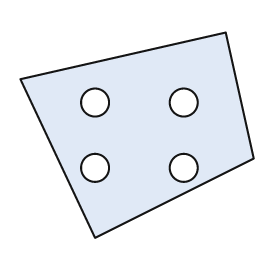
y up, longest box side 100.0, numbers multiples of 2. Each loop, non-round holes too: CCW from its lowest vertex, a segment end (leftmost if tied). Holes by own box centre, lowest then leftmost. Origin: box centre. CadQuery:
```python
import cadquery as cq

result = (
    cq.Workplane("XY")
    .moveTo(-18.0, -44.0)
    .lineTo(50.0, -10.0)
    .lineTo(38.0, 44.0)
    .lineTo(-50.0, 24.0)
    .close()
    .moveTo(-18.0, -14.0)
    .circle(6.0)
    .moveTo(20.0, -14.0)
    .circle(6.0)
    .moveTo(-18.0, 14.0)
    .circle(6.0)
    .moveTo(20.0, 14.0)
    .circle(6.0)
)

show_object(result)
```